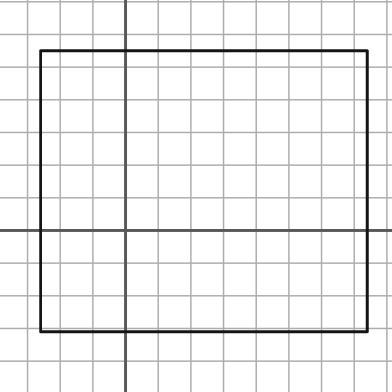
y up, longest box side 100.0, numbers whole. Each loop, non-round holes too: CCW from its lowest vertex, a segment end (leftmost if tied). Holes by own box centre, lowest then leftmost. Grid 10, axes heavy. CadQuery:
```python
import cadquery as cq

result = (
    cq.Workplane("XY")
    .moveTo(-26.0, -31.0)
    .lineTo(74.0, -31.0)
    .lineTo(74.0, 55.0)
    .lineTo(-26.0, 55.0)
    .close()
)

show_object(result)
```